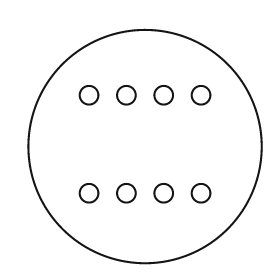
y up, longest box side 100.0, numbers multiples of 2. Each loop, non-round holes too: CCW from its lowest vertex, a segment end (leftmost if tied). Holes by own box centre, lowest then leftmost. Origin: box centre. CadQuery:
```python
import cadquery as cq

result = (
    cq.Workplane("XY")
    .moveTo(0.0, 0.0)
    .circle(50.0)
    .moveTo(-24.0, -20.0)
    .circle(4.0)
    .moveTo(-8.0, -20.0)
    .circle(4.0)
    .moveTo(8.0, -20.0)
    .circle(4.0)
    .moveTo(24.0, -20.0)
    .circle(4.0)
    .moveTo(-24.0, 22.0)
    .circle(4.0)
    .moveTo(-8.0, 22.0)
    .circle(4.0)
    .moveTo(8.0, 22.0)
    .circle(4.0)
    .moveTo(24.0, 22.0)
    .circle(4.0)
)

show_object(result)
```